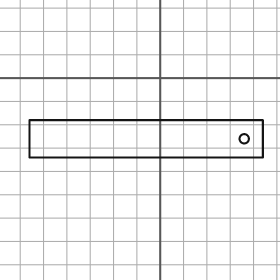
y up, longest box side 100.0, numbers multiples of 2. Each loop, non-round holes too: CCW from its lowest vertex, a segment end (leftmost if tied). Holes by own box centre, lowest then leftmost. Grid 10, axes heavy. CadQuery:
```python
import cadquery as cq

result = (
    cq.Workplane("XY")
    .moveTo(-56.0, -34.0)
    .lineTo(44.0, -34.0)
    .lineTo(44.0, -18.0)
    .lineTo(-56.0, -18.0)
    .close()
    .moveTo(36.0, -26.0)
    .circle(2.0)
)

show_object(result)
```